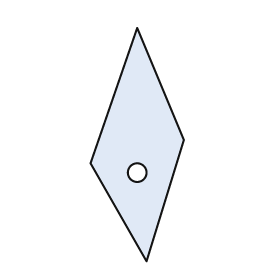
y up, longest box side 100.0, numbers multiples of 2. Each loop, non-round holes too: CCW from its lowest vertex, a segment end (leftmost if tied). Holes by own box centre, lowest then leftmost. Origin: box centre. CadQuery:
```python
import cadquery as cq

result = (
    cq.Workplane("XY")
    .moveTo(4.0, -50.0)
    .lineTo(20.0, 2.0)
    .lineTo(0.0, 50.0)
    .lineTo(-20.0, -8.0)
    .close()
    .moveTo(0.0, -12.0)
    .circle(4.0)
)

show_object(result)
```